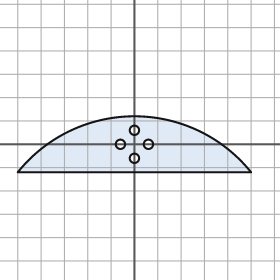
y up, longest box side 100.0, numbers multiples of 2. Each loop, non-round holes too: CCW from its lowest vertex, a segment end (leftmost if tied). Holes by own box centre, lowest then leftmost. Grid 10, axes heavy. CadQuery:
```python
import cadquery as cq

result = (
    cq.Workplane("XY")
    .moveTo(-50.0, -12.0)
    .lineTo(50.0, -12.0)
    .threePointArc((0.0, 12.0), (-50.0, -12.0))
    .close()
    .moveTo(0.0, -6.0)
    .circle(2.0)
    .moveTo(-6.0, 0.0)
    .circle(2.0)
    .moveTo(6.0, 0.0)
    .circle(2.0)
    .moveTo(0.0, 6.0)
    .circle(2.0)
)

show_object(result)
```